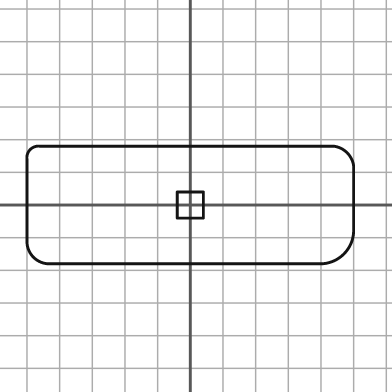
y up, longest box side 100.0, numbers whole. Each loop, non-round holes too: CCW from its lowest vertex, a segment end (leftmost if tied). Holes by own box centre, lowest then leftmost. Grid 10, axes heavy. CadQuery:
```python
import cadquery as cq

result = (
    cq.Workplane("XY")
    .moveTo(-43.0, -18.0)
    .lineTo(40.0, -18.0)
    .threePointArc((47.0, -15.0), (50.0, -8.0))
    .lineTo(50.0, 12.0)
    .threePointArc((48.0, 16.0), (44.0, 18.0))
    .lineTo(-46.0, 18.0)
    .threePointArc((-49.0, 17.0), (-50.0, 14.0))
    .lineTo(-50.0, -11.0)
    .threePointArc((-48.0, -16.0), (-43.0, -18.0))
    .close()
    .moveTo(-4.0, -4.0)
    .lineTo(4.0, -4.0)
    .lineTo(4.0, 4.0)
    .lineTo(-4.0, 4.0)
    .close()
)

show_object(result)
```